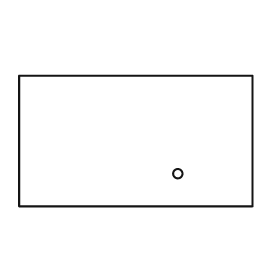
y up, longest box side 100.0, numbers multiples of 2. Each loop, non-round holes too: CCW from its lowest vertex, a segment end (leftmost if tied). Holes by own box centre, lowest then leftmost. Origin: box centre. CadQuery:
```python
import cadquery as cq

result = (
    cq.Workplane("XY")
    .moveTo(-50.0, -28.0)
    .lineTo(50.0, -28.0)
    .lineTo(50.0, 28.0)
    .lineTo(-50.0, 28.0)
    .close()
    .moveTo(18.0, -14.0)
    .circle(2.0)
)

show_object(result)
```